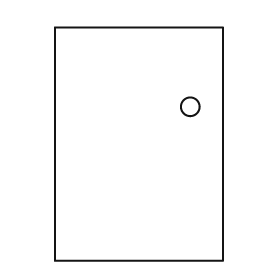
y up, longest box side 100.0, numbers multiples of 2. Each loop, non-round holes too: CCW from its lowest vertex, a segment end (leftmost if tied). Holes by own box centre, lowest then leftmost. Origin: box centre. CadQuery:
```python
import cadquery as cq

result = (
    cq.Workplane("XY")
    .moveTo(-36.0, -50.0)
    .lineTo(36.0, -50.0)
    .lineTo(36.0, 50.0)
    .lineTo(-36.0, 50.0)
    .close()
    .moveTo(22.0, 16.0)
    .circle(4.0)
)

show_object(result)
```